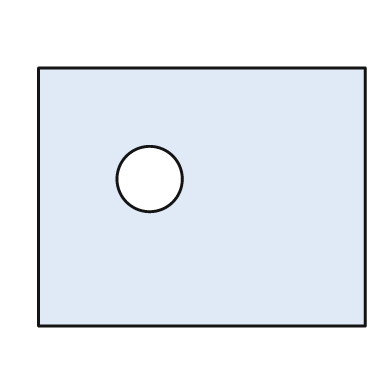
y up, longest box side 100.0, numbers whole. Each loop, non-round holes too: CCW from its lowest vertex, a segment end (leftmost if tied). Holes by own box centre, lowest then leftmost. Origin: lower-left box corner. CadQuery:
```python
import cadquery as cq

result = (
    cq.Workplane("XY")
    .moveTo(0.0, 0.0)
    .lineTo(100.0, 0.0)
    .lineTo(100.0, 79.0)
    .lineTo(0.0, 79.0)
    .close()
    .moveTo(34.0, 45.0)
    .circle(10.0)
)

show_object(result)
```